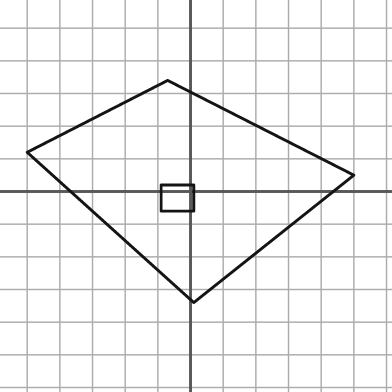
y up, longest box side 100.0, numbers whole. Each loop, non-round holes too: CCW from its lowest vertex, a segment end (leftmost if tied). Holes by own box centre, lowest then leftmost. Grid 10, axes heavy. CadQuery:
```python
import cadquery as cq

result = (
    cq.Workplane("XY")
    .moveTo(1.0, -34.0)
    .lineTo(50.0, 5.0)
    .lineTo(-7.0, 34.0)
    .lineTo(-50.0, 12.0)
    .close()
    .moveTo(-9.0, -6.0)
    .lineTo(1.0, -6.0)
    .lineTo(1.0, 2.0)
    .lineTo(-9.0, 2.0)
    .close()
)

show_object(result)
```